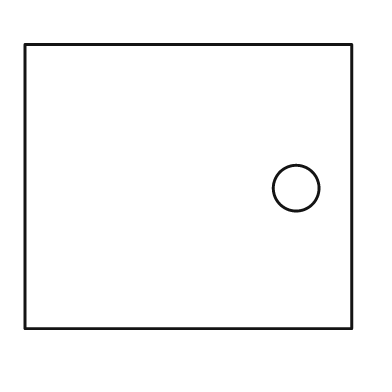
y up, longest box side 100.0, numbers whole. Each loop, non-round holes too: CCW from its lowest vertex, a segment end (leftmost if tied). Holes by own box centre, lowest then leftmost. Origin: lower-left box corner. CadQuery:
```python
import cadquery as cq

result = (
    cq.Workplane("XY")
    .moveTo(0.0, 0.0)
    .lineTo(100.0, 0.0)
    .lineTo(100.0, 87.0)
    .lineTo(0.0, 87.0)
    .close()
    .moveTo(83.0, 43.0)
    .circle(7.0)
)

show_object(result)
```